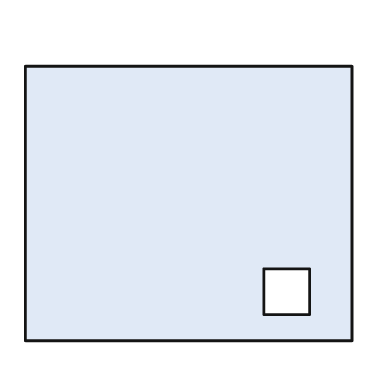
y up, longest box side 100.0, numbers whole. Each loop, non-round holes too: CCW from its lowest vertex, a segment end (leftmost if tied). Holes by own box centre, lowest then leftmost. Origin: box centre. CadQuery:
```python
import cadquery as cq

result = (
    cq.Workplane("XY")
    .moveTo(-50.0, -42.0)
    .lineTo(50.0, -42.0)
    .lineTo(50.0, 42.0)
    .lineTo(-50.0, 42.0)
    .close()
    .moveTo(23.0, -34.0)
    .lineTo(37.0, -34.0)
    .lineTo(37.0, -20.0)
    .lineTo(23.0, -20.0)
    .close()
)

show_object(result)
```